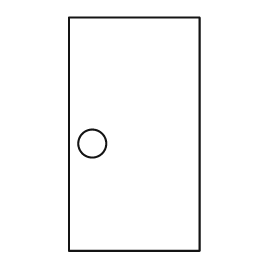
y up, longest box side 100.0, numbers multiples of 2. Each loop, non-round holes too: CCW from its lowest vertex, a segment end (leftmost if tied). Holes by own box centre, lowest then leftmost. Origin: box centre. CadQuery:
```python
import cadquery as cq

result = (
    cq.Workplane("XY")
    .moveTo(-28.0, -50.0)
    .lineTo(28.0, -50.0)
    .lineTo(28.0, 50.0)
    .lineTo(-28.0, 50.0)
    .close()
    .moveTo(-18.0, -4.0)
    .circle(6.0)
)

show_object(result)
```